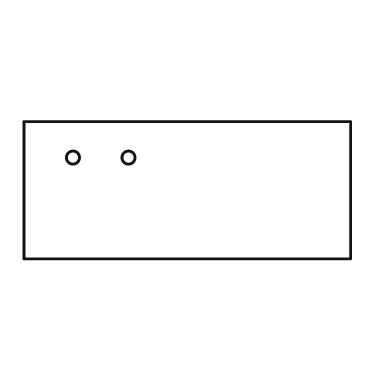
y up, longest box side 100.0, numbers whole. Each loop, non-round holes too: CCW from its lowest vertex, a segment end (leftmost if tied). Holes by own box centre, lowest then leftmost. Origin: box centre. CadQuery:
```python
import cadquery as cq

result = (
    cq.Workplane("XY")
    .moveTo(-50.0, -21.0)
    .lineTo(50.0, -21.0)
    .lineTo(50.0, 21.0)
    .lineTo(-50.0, 21.0)
    .close()
    .moveTo(-35.0, 10.0)
    .circle(2.0)
    .moveTo(-18.0, 10.0)
    .circle(2.0)
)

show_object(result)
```